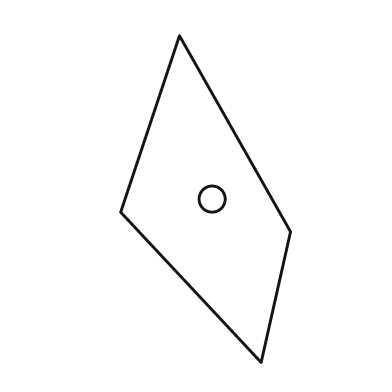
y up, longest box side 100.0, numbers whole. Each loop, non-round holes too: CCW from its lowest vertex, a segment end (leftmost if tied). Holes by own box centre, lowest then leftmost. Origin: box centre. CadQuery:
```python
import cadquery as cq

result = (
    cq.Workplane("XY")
    .moveTo(17.0, -50.0)
    .lineTo(26.0, -10.0)
    .lineTo(-8.0, 50.0)
    .lineTo(-26.0, -4.0)
    .close()
    .moveTo(2.0, 0.0)
    .circle(4.0)
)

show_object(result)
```